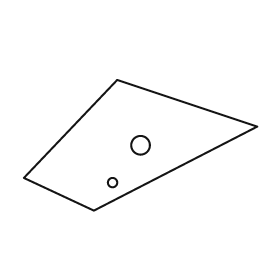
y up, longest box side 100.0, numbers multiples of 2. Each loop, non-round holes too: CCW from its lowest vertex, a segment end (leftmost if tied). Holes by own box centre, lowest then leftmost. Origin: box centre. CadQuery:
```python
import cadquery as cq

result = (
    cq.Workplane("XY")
    .moveTo(-20.0, -28.0)
    .lineTo(50.0, 8.0)
    .lineTo(-10.0, 28.0)
    .lineTo(-50.0, -14.0)
    .close()
    .moveTo(-12.0, -16.0)
    .circle(2.0)
    .moveTo(0.0, 0.0)
    .circle(4.0)
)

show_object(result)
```